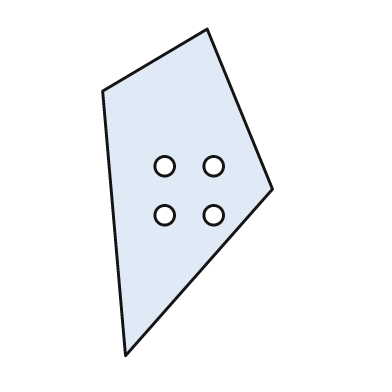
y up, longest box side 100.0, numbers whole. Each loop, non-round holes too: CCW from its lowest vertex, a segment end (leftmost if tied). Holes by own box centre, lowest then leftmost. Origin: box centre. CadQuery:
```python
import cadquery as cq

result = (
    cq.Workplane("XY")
    .moveTo(-19.0, -50.0)
    .lineTo(26.0, 1.0)
    .lineTo(6.0, 50.0)
    .lineTo(-26.0, 31.0)
    .close()
    .moveTo(-7.0, -7.0)
    .circle(3.0)
    .moveTo(8.0, -7.0)
    .circle(3.0)
    .moveTo(-7.0, 8.0)
    .circle(3.0)
    .moveTo(8.0, 8.0)
    .circle(3.0)
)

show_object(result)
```